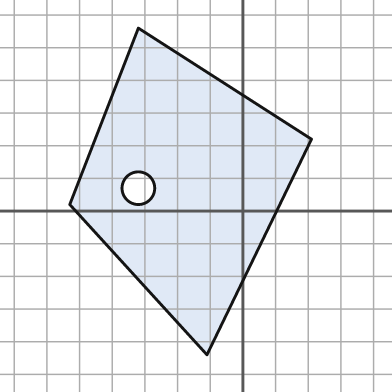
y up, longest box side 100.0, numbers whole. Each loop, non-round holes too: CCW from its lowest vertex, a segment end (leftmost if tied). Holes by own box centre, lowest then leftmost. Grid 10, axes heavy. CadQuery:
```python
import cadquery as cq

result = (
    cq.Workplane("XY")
    .moveTo(-11.0, -44.0)
    .lineTo(21.0, 22.0)
    .lineTo(-32.0, 56.0)
    .lineTo(-53.0, 2.0)
    .close()
    .moveTo(-32.0, 7.0)
    .circle(5.0)
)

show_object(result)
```